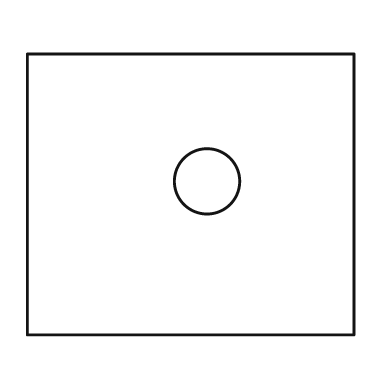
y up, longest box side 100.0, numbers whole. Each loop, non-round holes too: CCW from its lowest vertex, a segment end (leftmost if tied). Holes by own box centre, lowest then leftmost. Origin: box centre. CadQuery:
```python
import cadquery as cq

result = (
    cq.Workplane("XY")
    .moveTo(-50.0, -43.0)
    .lineTo(50.0, -43.0)
    .lineTo(50.0, 43.0)
    .lineTo(-50.0, 43.0)
    .close()
    .moveTo(5.0, 4.0)
    .circle(10.0)
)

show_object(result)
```